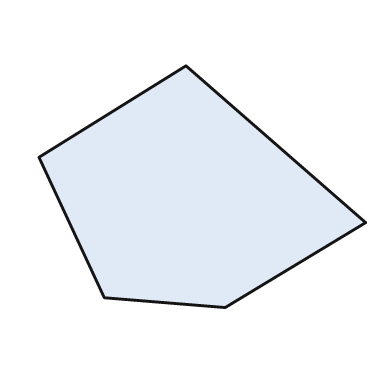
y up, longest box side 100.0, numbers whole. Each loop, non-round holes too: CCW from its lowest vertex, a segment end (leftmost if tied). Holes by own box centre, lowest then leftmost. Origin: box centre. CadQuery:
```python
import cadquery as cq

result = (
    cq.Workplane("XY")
    .moveTo(7.0, -37.0)
    .lineTo(50.0, -11.0)
    .lineTo(-5.0, 37.0)
    .lineTo(-50.0, 9.0)
    .lineTo(-30.0, -34.0)
    .close()
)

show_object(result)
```